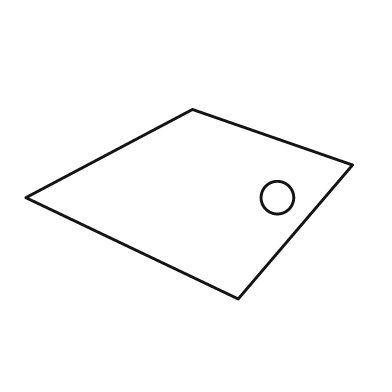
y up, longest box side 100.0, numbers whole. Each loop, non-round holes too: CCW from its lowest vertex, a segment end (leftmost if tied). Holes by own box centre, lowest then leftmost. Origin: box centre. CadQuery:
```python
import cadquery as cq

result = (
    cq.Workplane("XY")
    .moveTo(15.0, -29.0)
    .lineTo(50.0, 12.0)
    .lineTo(1.0, 29.0)
    .lineTo(-50.0, 2.0)
    .close()
    .moveTo(27.0, 2.0)
    .circle(5.0)
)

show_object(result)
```